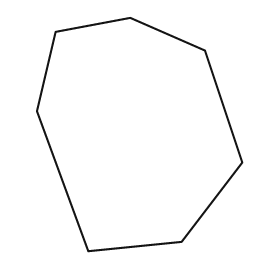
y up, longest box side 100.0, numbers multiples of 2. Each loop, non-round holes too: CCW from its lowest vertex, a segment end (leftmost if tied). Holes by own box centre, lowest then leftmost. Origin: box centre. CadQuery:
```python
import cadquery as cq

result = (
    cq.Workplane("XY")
    .moveTo(-22.0, -50.0)
    .lineTo(18.0, -46.0)
    .lineTo(44.0, -12.0)
    .lineTo(28.0, 36.0)
    .lineTo(-4.0, 50.0)
    .lineTo(-36.0, 44.0)
    .lineTo(-44.0, 10.0)
    .close()
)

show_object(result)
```